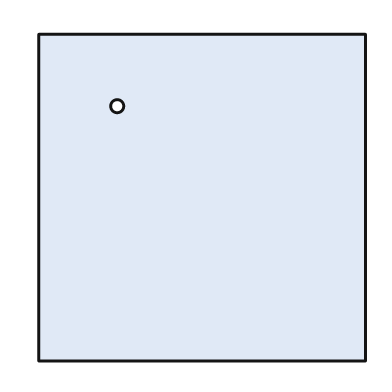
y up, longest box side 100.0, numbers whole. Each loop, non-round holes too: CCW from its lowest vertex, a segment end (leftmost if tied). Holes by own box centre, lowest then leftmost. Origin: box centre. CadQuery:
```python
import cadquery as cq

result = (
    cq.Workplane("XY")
    .moveTo(-50.0, -50.0)
    .lineTo(50.0, -50.0)
    .lineTo(50.0, 50.0)
    .lineTo(-50.0, 50.0)
    .close()
    .moveTo(-26.0, 28.0)
    .circle(2.0)
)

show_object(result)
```